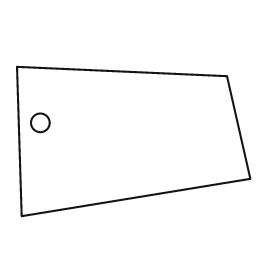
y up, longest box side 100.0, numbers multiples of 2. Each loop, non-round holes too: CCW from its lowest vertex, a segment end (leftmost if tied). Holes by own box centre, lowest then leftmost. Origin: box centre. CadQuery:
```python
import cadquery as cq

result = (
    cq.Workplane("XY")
    .moveTo(-48.0, -32.0)
    .lineTo(50.0, -16.0)
    .lineTo(40.0, 28.0)
    .lineTo(-50.0, 32.0)
    .close()
    .moveTo(-40.0, 8.0)
    .circle(4.0)
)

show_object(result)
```